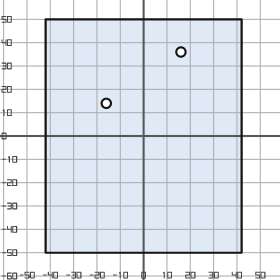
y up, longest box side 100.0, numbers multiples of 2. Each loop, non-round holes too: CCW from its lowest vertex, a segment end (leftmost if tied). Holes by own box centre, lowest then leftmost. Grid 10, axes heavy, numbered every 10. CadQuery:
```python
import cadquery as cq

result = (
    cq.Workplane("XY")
    .moveTo(-42.0, -50.0)
    .lineTo(42.0, -50.0)
    .lineTo(42.0, 50.0)
    .lineTo(-42.0, 50.0)
    .close()
    .moveTo(-16.0, 14.0)
    .circle(2.0)
    .moveTo(16.0, 36.0)
    .circle(2.0)
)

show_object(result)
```